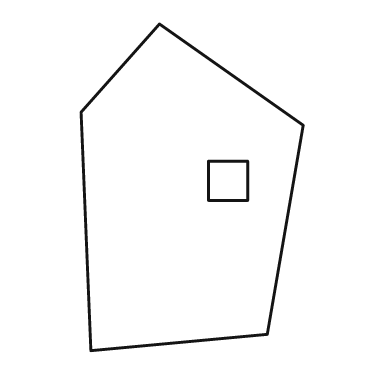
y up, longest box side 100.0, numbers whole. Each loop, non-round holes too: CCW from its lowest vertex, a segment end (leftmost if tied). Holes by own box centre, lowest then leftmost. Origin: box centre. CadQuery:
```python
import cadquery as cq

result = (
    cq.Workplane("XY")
    .moveTo(-31.0, -50.0)
    .lineTo(23.0, -45.0)
    .lineTo(34.0, 19.0)
    .lineTo(-10.0, 50.0)
    .lineTo(-34.0, 23.0)
    .close()
    .moveTo(5.0, -4.0)
    .lineTo(17.0, -4.0)
    .lineTo(17.0, 8.0)
    .lineTo(5.0, 8.0)
    .close()
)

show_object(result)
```